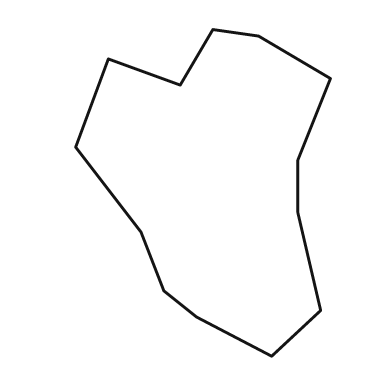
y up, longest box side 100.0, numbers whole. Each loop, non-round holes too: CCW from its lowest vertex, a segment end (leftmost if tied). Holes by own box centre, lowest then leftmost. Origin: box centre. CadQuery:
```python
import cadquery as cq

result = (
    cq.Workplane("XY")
    .moveTo(21.0, -50.0)
    .lineTo(36.0, -36.0)
    .lineTo(29.0, -6.0)
    .lineTo(29.0, 10.0)
    .lineTo(39.0, 35.0)
    .lineTo(17.0, 48.0)
    .lineTo(3.0, 50.0)
    .lineTo(-7.0, 33.0)
    .lineTo(-29.0, 41.0)
    .lineTo(-39.0, 14.0)
    .lineTo(-19.0, -12.0)
    .lineTo(-12.0, -30.0)
    .lineTo(-2.0, -38.0)
    .close()
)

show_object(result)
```